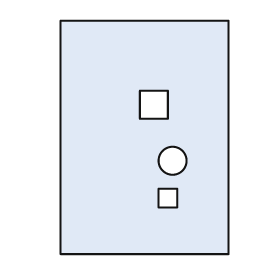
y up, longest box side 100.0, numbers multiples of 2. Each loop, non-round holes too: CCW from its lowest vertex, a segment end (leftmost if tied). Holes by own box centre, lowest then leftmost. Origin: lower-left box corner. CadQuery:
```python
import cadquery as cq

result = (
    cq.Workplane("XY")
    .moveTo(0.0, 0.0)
    .lineTo(72.0, 0.0)
    .lineTo(72.0, 100.0)
    .lineTo(0.0, 100.0)
    .close()
    .moveTo(42.0, 20.0)
    .lineTo(50.0, 20.0)
    .lineTo(50.0, 28.0)
    .lineTo(42.0, 28.0)
    .close()
    .moveTo(48.0, 40.0)
    .circle(6.0)
    .moveTo(34.0, 58.0)
    .lineTo(46.0, 58.0)
    .lineTo(46.0, 70.0)
    .lineTo(34.0, 70.0)
    .close()
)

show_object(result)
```